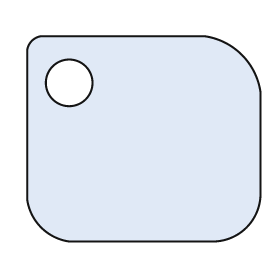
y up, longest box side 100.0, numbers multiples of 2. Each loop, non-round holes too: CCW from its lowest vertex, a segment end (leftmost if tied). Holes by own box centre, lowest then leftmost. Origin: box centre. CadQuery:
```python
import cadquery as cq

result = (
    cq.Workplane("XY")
    .moveTo(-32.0, -44.0)
    .lineTo(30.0, -44.0)
    .threePointArc((44.0, -38.0), (50.0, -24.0))
    .lineTo(50.0, 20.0)
    .threePointArc((42.0, 36.0), (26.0, 44.0))
    .lineTo(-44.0, 44.0)
    .threePointArc((-48.0, 42.0), (-50.0, 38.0))
    .lineTo(-50.0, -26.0)
    .threePointArc((-44.0, -38.0), (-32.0, -44.0))
    .close()
    .moveTo(-32.0, 24.0)
    .circle(10.0)
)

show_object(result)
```